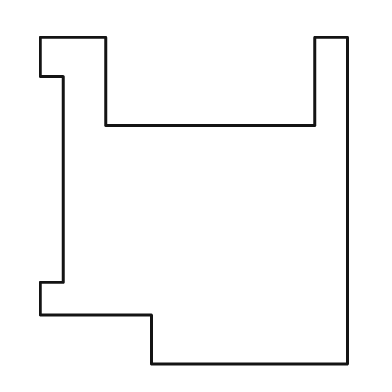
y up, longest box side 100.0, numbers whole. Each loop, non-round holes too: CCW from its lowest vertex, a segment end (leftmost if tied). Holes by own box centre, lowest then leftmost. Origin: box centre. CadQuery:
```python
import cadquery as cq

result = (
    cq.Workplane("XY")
    .moveTo(-13.0, -50.0)
    .lineTo(47.0, -50.0)
    .lineTo(47.0, 50.0)
    .lineTo(37.0, 50.0)
    .lineTo(37.0, 23.0)
    .lineTo(-27.0, 23.0)
    .lineTo(-27.0, 50.0)
    .lineTo(-47.0, 50.0)
    .lineTo(-47.0, 38.0)
    .lineTo(-40.0, 38.0)
    .lineTo(-40.0, -25.0)
    .lineTo(-47.0, -25.0)
    .lineTo(-47.0, -35.0)
    .lineTo(-13.0, -35.0)
    .close()
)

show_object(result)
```